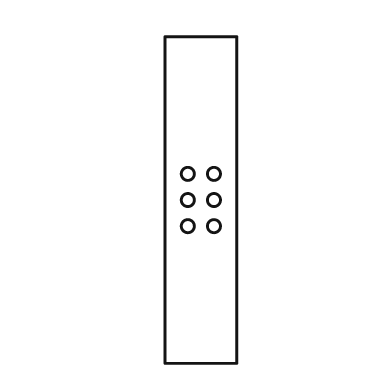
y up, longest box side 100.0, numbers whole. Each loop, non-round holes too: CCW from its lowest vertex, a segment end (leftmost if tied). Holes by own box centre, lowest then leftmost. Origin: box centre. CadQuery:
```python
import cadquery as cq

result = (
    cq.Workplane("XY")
    .moveTo(-11.0, -50.0)
    .lineTo(11.0, -50.0)
    .lineTo(11.0, 50.0)
    .lineTo(-11.0, 50.0)
    .close()
    .moveTo(-4.0, -8.0)
    .circle(2.0)
    .moveTo(4.0, -8.0)
    .circle(2.0)
    .moveTo(-4.0, 0.0)
    .circle(2.0)
    .moveTo(4.0, 0.0)
    .circle(2.0)
    .moveTo(-4.0, 8.0)
    .circle(2.0)
    .moveTo(4.0, 8.0)
    .circle(2.0)
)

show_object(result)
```